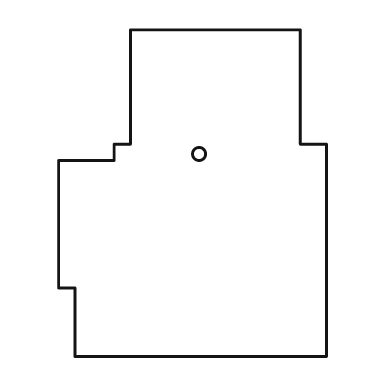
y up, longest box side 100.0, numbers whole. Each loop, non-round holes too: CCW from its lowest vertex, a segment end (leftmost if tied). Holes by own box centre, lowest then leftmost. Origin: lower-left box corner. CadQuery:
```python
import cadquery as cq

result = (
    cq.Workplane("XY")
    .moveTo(5.0, 0.0)
    .lineTo(82.0, 0.0)
    .lineTo(82.0, 65.0)
    .lineTo(74.0, 65.0)
    .lineTo(74.0, 100.0)
    .lineTo(22.0, 100.0)
    .lineTo(22.0, 65.0)
    .lineTo(17.0, 65.0)
    .lineTo(17.0, 60.0)
    .lineTo(0.0, 60.0)
    .lineTo(0.0, 21.0)
    .lineTo(5.0, 21.0)
    .close()
    .moveTo(43.0, 62.0)
    .circle(2.0)
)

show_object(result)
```